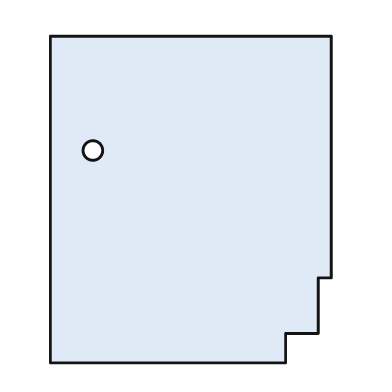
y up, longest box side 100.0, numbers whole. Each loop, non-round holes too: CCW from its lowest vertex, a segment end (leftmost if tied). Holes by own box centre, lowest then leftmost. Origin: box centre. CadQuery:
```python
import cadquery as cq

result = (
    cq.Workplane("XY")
    .moveTo(-43.0, -50.0)
    .lineTo(29.0, -50.0)
    .lineTo(29.0, -41.0)
    .lineTo(39.0, -41.0)
    .lineTo(39.0, -24.0)
    .lineTo(43.0, -24.0)
    .lineTo(43.0, 50.0)
    .lineTo(-43.0, 50.0)
    .close()
    .moveTo(-30.0, 15.0)
    .circle(3.0)
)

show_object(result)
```